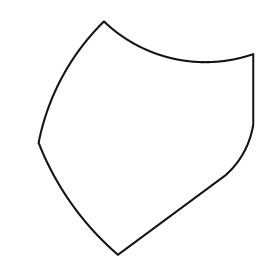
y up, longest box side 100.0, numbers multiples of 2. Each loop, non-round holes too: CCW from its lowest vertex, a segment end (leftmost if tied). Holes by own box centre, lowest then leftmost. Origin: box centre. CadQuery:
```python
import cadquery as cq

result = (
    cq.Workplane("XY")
    .moveTo(-12.0, -50.0)
    .lineTo(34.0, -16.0)
    .threePointArc((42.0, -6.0), (46.0, 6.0))
    .lineTo(46.0, 36.0)
    .threePointArc((12.0, 34.0), (-18.0, 50.0))
    .threePointArc((-36.0, 26.0), (-46.0, -2.0))
    .threePointArc((-32.0, -28.0), (-12.0, -50.0))
    .close()
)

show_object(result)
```